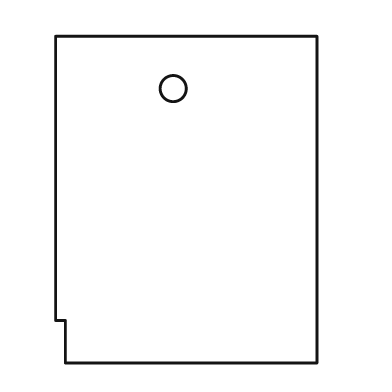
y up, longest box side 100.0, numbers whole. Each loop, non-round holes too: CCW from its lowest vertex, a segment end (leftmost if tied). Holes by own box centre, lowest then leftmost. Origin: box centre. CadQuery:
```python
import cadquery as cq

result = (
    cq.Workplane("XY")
    .moveTo(-37.0, -50.0)
    .lineTo(40.0, -50.0)
    .lineTo(40.0, 50.0)
    .lineTo(-40.0, 50.0)
    .lineTo(-40.0, -37.0)
    .lineTo(-37.0, -37.0)
    .close()
    .moveTo(-4.0, 34.0)
    .circle(4.0)
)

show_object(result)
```